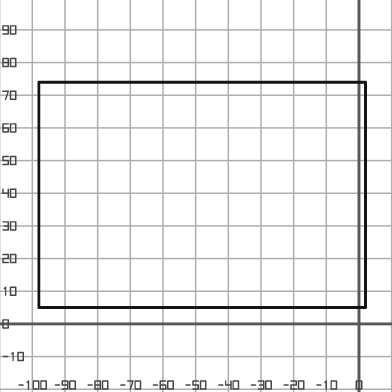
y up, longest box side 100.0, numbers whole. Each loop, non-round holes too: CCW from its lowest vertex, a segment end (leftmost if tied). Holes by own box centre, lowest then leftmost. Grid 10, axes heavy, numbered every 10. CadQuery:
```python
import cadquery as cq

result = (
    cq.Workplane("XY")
    .moveTo(-98.0, 5.0)
    .lineTo(2.0, 5.0)
    .lineTo(2.0, 74.0)
    .lineTo(-98.0, 74.0)
    .close()
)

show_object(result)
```